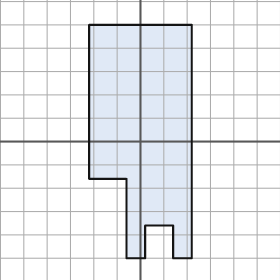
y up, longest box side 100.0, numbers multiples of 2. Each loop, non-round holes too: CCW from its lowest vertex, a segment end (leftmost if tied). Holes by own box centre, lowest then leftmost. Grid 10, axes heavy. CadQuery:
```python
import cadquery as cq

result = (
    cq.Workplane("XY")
    .moveTo(-6.0, -50.0)
    .lineTo(2.0, -50.0)
    .lineTo(2.0, -36.0)
    .lineTo(14.0, -36.0)
    .lineTo(14.0, -50.0)
    .lineTo(22.0, -50.0)
    .lineTo(22.0, 50.0)
    .lineTo(-22.0, 50.0)
    .lineTo(-22.0, -16.0)
    .lineTo(-6.0, -16.0)
    .close()
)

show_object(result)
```